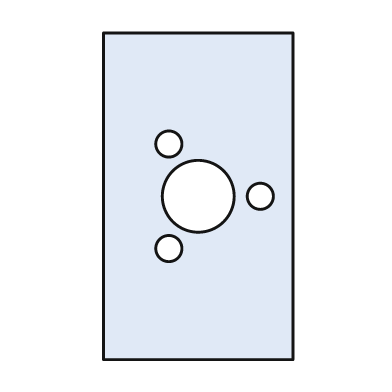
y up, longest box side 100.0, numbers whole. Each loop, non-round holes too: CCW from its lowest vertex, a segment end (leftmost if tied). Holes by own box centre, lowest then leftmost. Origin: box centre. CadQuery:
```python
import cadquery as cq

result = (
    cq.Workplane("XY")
    .moveTo(-29.0, -50.0)
    .lineTo(29.0, -50.0)
    .lineTo(29.0, 50.0)
    .lineTo(-29.0, 50.0)
    .close()
    .moveTo(-9.0, -16.0)
    .circle(4.0)
    .moveTo(0.0, 0.0)
    .circle(11.0)
    .moveTo(19.0, 0.0)
    .circle(4.0)
    .moveTo(-9.0, 16.0)
    .circle(4.0)
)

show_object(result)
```